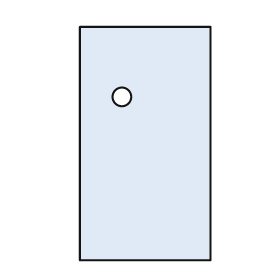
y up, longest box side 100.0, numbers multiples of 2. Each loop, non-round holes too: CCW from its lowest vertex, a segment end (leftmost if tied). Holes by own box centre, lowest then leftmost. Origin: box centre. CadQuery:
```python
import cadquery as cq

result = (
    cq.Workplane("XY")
    .moveTo(-28.0, -50.0)
    .lineTo(28.0, -50.0)
    .lineTo(28.0, 50.0)
    .lineTo(-28.0, 50.0)
    .close()
    .moveTo(-10.0, 20.0)
    .circle(4.0)
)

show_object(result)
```